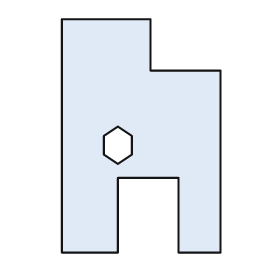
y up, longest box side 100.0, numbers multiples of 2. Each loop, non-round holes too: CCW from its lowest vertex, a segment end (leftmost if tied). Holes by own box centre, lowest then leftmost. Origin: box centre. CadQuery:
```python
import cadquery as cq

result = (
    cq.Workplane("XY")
    .moveTo(-34.0, -50.0)
    .lineTo(-10.0, -50.0)
    .lineTo(-10.0, -18.0)
    .lineTo(16.0, -18.0)
    .lineTo(16.0, -50.0)
    .lineTo(34.0, -50.0)
    .lineTo(34.0, 28.0)
    .lineTo(4.0, 28.0)
    .lineTo(4.0, 50.0)
    .lineTo(-34.0, 50.0)
    .close()
    .moveTo(-10.0, -12.0)
    .lineTo(-4.0, -8.0)
    .lineTo(-4.0, 0.0)
    .lineTo(-10.0, 4.0)
    .lineTo(-16.0, 0.0)
    .lineTo(-16.0, -8.0)
    .close()
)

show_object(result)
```